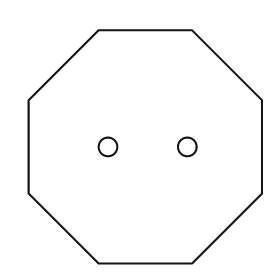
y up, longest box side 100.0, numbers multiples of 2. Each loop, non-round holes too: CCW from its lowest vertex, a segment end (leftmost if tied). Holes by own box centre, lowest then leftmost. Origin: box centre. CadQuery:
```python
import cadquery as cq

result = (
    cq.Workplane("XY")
    .moveTo(-20.0, -50.0)
    .lineTo(20.0, -50.0)
    .lineTo(50.0, -20.0)
    .lineTo(50.0, 20.0)
    .lineTo(20.0, 50.0)
    .lineTo(-20.0, 50.0)
    .lineTo(-50.0, 20.0)
    .lineTo(-50.0, -20.0)
    .close()
    .moveTo(-16.0, 0.0)
    .circle(4.0)
    .moveTo(18.0, 0.0)
    .circle(4.0)
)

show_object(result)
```